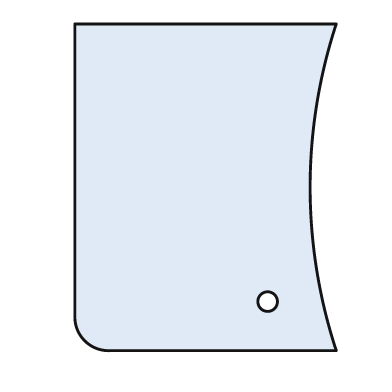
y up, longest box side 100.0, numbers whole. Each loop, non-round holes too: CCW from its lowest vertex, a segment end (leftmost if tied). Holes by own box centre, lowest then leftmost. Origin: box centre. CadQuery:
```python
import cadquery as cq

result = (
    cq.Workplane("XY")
    .moveTo(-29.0, -50.0)
    .lineTo(40.0, -50.0)
    .threePointArc((32.0, 0.0), (40.0, 50.0))
    .lineTo(-40.0, 50.0)
    .lineTo(-40.0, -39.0)
    .threePointArc((-37.0, -47.0), (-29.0, -50.0))
    .close()
    .moveTo(19.0, -35.0)
    .circle(3.0)
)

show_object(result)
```